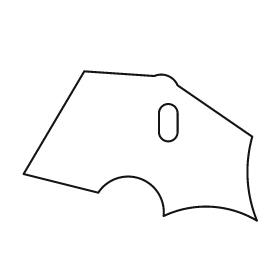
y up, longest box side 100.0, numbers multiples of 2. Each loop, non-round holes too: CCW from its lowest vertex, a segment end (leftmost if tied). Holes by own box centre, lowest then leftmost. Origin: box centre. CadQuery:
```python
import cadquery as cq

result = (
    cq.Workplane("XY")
    .moveTo(50.0, -32.0)
    .threePointArc((46.0, -14.0), (48.0, 4.0))
    .lineTo(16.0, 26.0)
    .threePointArc((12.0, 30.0), (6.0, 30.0))
    .lineTo(-24.0, 32.0)
    .lineTo(-50.0, -12.0)
    .lineTo(-18.0, -20.0)
    .threePointArc((0.0, -14.0), (10.0, -30.0))
    .threePointArc((30.0, -26.0), (50.0, -32.0))
    .close()
    .moveTo(8.0, 6.0)
    .threePointArc((12.0, 2.0), (16.0, 6.0))
    .lineTo(16.0, 14.0)
    .threePointArc((12.0, 18.0), (8.0, 14.0))
    .close()
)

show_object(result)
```